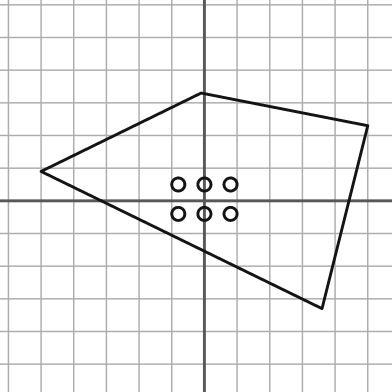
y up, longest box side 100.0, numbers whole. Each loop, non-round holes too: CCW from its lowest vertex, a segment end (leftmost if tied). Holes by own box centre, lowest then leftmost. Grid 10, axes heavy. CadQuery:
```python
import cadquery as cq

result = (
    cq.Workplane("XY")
    .moveTo(36.0, -33.0)
    .lineTo(50.0, 23.0)
    .lineTo(-1.0, 33.0)
    .lineTo(-50.0, 9.0)
    .close()
    .moveTo(-8.0, -4.0)
    .circle(2.0)
    .moveTo(0.0, -4.0)
    .circle(2.0)
    .moveTo(8.0, -4.0)
    .circle(2.0)
    .moveTo(-8.0, 5.0)
    .circle(2.0)
    .moveTo(0.0, 5.0)
    .circle(2.0)
    .moveTo(8.0, 5.0)
    .circle(2.0)
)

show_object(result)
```